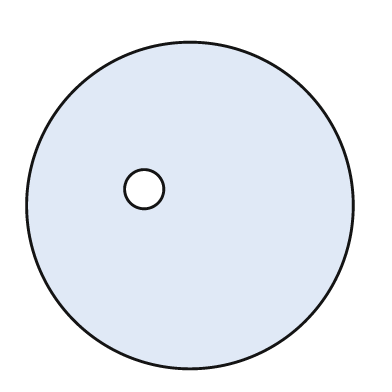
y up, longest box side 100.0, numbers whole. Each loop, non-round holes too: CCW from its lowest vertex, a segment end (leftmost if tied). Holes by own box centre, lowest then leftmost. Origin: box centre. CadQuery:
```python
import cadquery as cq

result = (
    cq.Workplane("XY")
    .moveTo(0.0, 0.0)
    .circle(50.0)
    .moveTo(-14.0, 5.0)
    .circle(6.0)
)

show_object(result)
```